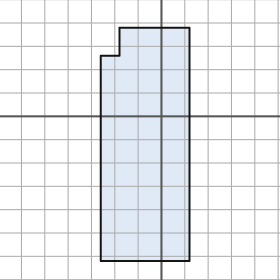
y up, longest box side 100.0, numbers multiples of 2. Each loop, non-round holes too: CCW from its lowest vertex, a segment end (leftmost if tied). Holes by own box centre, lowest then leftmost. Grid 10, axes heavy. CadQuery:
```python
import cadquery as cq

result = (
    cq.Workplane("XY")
    .moveTo(-26.0, -62.0)
    .lineTo(12.0, -62.0)
    .lineTo(12.0, 38.0)
    .lineTo(-18.0, 38.0)
    .lineTo(-18.0, 26.0)
    .lineTo(-26.0, 26.0)
    .close()
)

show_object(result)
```